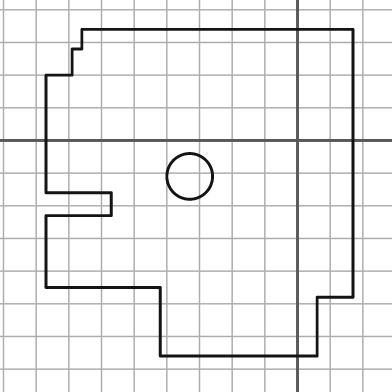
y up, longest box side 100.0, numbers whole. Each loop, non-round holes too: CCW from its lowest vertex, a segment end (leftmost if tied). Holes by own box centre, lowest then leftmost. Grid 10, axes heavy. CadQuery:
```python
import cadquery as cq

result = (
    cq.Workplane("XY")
    .moveTo(-42.0, -66.0)
    .lineTo(6.0, -66.0)
    .lineTo(6.0, -48.0)
    .lineTo(17.0, -48.0)
    .lineTo(17.0, 34.0)
    .lineTo(-66.0, 34.0)
    .lineTo(-66.0, 28.0)
    .lineTo(-69.0, 28.0)
    .lineTo(-69.0, 20.0)
    .lineTo(-77.0, 20.0)
    .lineTo(-77.0, -16.0)
    .lineTo(-57.0, -16.0)
    .lineTo(-57.0, -23.0)
    .lineTo(-77.0, -23.0)
    .lineTo(-77.0, -45.0)
    .lineTo(-42.0, -45.0)
    .close()
    .moveTo(-33.0, -11.0)
    .circle(7.0)
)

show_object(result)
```